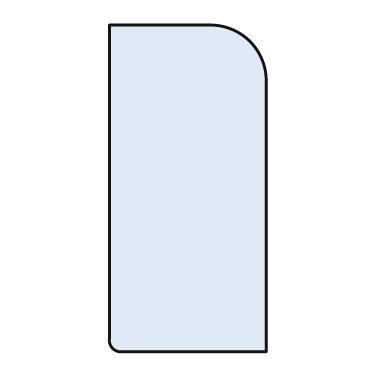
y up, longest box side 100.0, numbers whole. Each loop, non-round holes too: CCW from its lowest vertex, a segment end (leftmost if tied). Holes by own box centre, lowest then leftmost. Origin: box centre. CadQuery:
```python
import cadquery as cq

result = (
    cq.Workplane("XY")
    .moveTo(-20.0, -50.0)
    .lineTo(24.0, -50.0)
    .lineTo(24.0, 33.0)
    .threePointArc((19.0, 45.0), (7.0, 50.0))
    .lineTo(-24.0, 50.0)
    .lineTo(-24.0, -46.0)
    .threePointArc((-23.0, -49.0), (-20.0, -50.0))
    .close()
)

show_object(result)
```